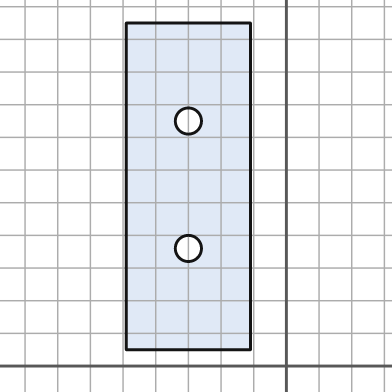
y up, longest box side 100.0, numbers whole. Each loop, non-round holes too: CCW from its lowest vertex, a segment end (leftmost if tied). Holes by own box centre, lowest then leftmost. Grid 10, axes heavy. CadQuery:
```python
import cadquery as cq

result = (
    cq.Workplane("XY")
    .moveTo(-49.0, 5.0)
    .lineTo(-11.0, 5.0)
    .lineTo(-11.0, 105.0)
    .lineTo(-49.0, 105.0)
    .close()
    .moveTo(-30.0, 36.0)
    .circle(4.0)
    .moveTo(-30.0, 75.0)
    .circle(4.0)
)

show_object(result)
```